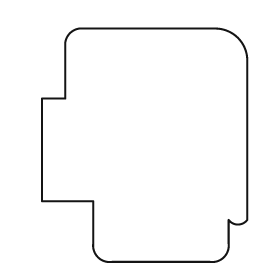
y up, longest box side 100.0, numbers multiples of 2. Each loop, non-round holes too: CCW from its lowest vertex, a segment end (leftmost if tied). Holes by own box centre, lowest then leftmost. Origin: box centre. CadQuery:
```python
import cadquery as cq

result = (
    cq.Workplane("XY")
    .moveTo(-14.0, -50.0)
    .lineTo(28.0, -50.0)
    .threePointArc((34.0, -48.0), (36.0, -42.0))
    .lineTo(36.0, -32.0)
    .threePointArc((40.0, -34.0), (44.0, -32.0))
    .lineTo(44.0, 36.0)
    .threePointArc((40.0, 46.0), (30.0, 50.0))
    .lineTo(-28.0, 50.0)
    .threePointArc((-32.0, 48.0), (-34.0, 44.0))
    .lineTo(-34.0, 20.0)
    .lineTo(-44.0, 20.0)
    .lineTo(-44.0, -24.0)
    .lineTo(-22.0, -24.0)
    .lineTo(-22.0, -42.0)
    .threePointArc((-20.0, -48.0), (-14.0, -50.0))
    .close()
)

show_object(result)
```